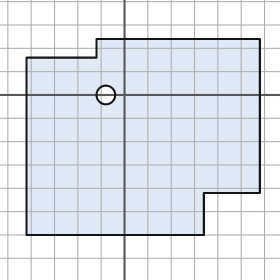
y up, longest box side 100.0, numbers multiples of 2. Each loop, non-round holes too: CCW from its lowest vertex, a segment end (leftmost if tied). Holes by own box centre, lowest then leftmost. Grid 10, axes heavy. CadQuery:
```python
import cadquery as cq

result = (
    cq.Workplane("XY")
    .moveTo(-42.0, -60.0)
    .lineTo(34.0, -60.0)
    .lineTo(34.0, -42.0)
    .lineTo(58.0, -42.0)
    .lineTo(58.0, 24.0)
    .lineTo(-12.0, 24.0)
    .lineTo(-12.0, 16.0)
    .lineTo(-42.0, 16.0)
    .close()
    .moveTo(-8.0, 0.0)
    .circle(4.0)
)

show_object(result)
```